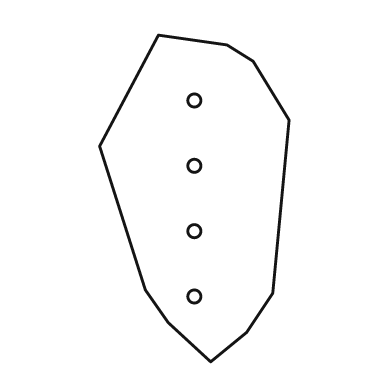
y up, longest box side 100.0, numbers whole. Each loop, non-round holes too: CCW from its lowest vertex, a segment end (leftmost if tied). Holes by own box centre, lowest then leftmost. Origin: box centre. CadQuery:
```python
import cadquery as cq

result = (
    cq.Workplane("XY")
    .moveTo(5.0, -50.0)
    .lineTo(16.0, -41.0)
    .lineTo(24.0, -29.0)
    .lineTo(29.0, 24.0)
    .lineTo(18.0, 42.0)
    .lineTo(10.0, 47.0)
    .lineTo(-11.0, 50.0)
    .lineTo(-29.0, 16.0)
    .lineTo(-15.0, -28.0)
    .lineTo(-8.0, -38.0)
    .close()
    .moveTo(0.0, -30.0)
    .circle(2.0)
    .moveTo(0.0, -10.0)
    .circle(2.0)
    .moveTo(0.0, 10.0)
    .circle(2.0)
    .moveTo(0.0, 30.0)
    .circle(2.0)
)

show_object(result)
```